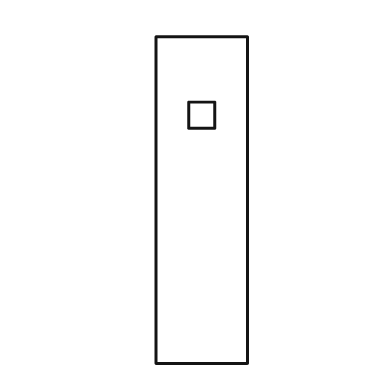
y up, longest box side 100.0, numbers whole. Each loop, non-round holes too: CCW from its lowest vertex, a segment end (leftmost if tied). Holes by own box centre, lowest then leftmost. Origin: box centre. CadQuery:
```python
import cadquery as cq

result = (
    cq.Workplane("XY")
    .moveTo(-14.0, -50.0)
    .lineTo(14.0, -50.0)
    .lineTo(14.0, 50.0)
    .lineTo(-14.0, 50.0)
    .close()
    .moveTo(-4.0, 22.0)
    .lineTo(4.0, 22.0)
    .lineTo(4.0, 30.0)
    .lineTo(-4.0, 30.0)
    .close()
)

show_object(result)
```